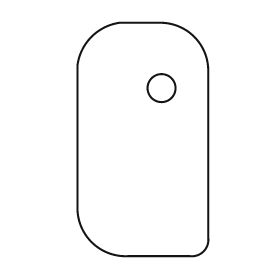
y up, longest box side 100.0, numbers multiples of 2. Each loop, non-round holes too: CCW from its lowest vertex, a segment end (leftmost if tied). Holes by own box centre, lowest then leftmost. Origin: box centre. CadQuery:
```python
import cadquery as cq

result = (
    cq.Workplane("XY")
    .moveTo(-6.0, -50.0)
    .lineTo(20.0, -50.0)
    .threePointArc((26.0, -48.0), (28.0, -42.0))
    .lineTo(28.0, 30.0)
    .threePointArc((22.0, 44.0), (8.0, 50.0))
    .lineTo(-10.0, 50.0)
    .threePointArc((-22.0, 44.0), (-28.0, 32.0))
    .lineTo(-28.0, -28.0)
    .threePointArc((-22.0, -44.0), (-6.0, -50.0))
    .close()
    .moveTo(8.0, 22.0)
    .circle(6.0)
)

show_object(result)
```